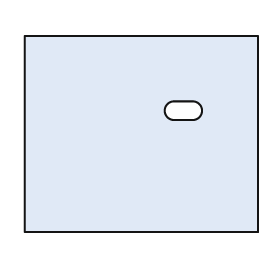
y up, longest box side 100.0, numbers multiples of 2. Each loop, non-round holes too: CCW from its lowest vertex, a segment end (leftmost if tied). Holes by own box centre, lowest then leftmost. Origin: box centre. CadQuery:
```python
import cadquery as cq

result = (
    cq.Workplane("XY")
    .moveTo(-50.0, -42.0)
    .lineTo(50.0, -42.0)
    .lineTo(50.0, 42.0)
    .lineTo(-50.0, 42.0)
    .close()
    .moveTo(14.0, 6.0)
    .lineTo(22.0, 6.0)
    .threePointArc((26.0, 10.0), (22.0, 14.0))
    .lineTo(14.0, 14.0)
    .threePointArc((10.0, 10.0), (14.0, 6.0))
    .close()
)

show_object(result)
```